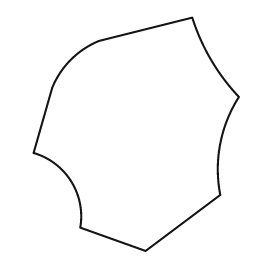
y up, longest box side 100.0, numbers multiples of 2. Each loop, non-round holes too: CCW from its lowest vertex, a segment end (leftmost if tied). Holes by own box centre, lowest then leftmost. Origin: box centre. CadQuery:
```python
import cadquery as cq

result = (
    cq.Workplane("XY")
    .moveTo(4.0, -50.0)
    .lineTo(36.0, -26.0)
    .threePointArc((36.0, -4.0), (44.0, 16.0))
    .threePointArc((32.0, 32.0), (24.0, 50.0))
    .lineTo(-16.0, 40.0)
    .threePointArc((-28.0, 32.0), (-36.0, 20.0))
    .lineTo(-44.0, -8.0)
    .threePointArc((-28.0, -20.0), (-24.0, -40.0))
    .close()
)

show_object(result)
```